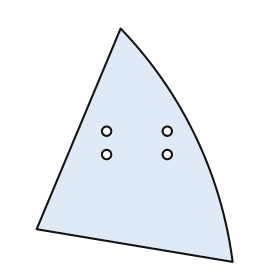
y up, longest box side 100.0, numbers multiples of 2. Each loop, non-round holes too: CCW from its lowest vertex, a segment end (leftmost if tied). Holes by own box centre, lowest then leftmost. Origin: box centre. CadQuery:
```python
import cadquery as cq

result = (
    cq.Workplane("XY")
    .moveTo(42.0, -50.0)
    .threePointArc((26.0, 4.0), (-6.0, 50.0))
    .lineTo(-42.0, -36.0)
    .close()
    .moveTo(-12.0, -4.0)
    .circle(2.0)
    .moveTo(14.0, -4.0)
    .circle(2.0)
    .moveTo(-12.0, 6.0)
    .circle(2.0)
    .moveTo(14.0, 6.0)
    .circle(2.0)
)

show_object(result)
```